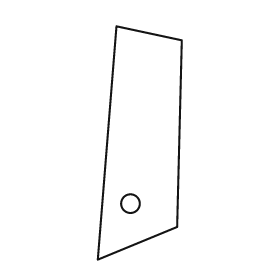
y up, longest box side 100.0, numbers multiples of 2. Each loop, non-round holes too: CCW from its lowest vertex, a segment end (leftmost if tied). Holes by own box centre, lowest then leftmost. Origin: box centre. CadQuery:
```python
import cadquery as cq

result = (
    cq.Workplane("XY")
    .moveTo(-18.0, -50.0)
    .lineTo(16.0, -36.0)
    .lineTo(18.0, 44.0)
    .lineTo(-10.0, 50.0)
    .close()
    .moveTo(-4.0, -26.0)
    .circle(4.0)
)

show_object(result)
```